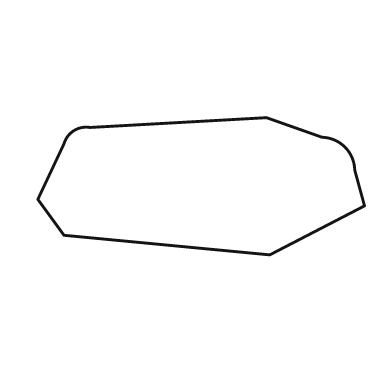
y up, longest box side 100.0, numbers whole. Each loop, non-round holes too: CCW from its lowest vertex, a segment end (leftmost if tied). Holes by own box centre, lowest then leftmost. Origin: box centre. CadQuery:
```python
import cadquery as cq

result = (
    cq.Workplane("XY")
    .moveTo(21.0, -21.0)
    .lineTo(50.0, -6.0)
    .lineTo(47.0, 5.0)
    .threePointArc((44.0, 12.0), (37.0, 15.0))
    .lineTo(20.0, 21.0)
    .lineTo(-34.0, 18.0)
    .threePointArc((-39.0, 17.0), (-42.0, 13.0))
    .lineTo(-50.0, -4.0)
    .lineTo(-42.0, -15.0)
    .close()
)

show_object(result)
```